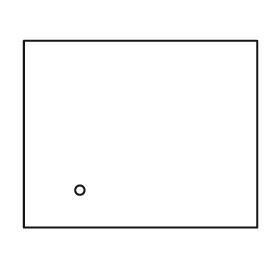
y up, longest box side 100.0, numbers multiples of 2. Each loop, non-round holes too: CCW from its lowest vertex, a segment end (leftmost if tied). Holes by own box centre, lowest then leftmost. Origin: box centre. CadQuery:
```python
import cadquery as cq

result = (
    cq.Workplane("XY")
    .moveTo(-50.0, -40.0)
    .lineTo(50.0, -40.0)
    .lineTo(50.0, 40.0)
    .lineTo(-50.0, 40.0)
    .close()
    .moveTo(-26.0, -24.0)
    .circle(2.0)
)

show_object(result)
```